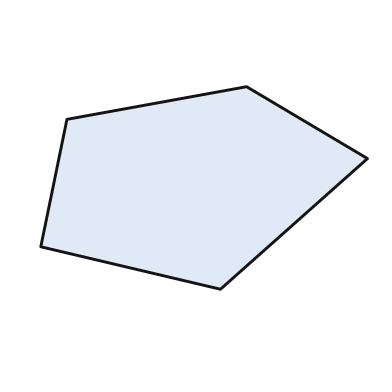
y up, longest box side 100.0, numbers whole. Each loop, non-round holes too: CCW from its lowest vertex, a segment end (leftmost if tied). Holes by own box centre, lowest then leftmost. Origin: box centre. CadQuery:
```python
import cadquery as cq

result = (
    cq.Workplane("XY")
    .moveTo(5.0, -31.0)
    .lineTo(50.0, 9.0)
    .lineTo(13.0, 31.0)
    .lineTo(-42.0, 21.0)
    .lineTo(-50.0, -18.0)
    .close()
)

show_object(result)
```